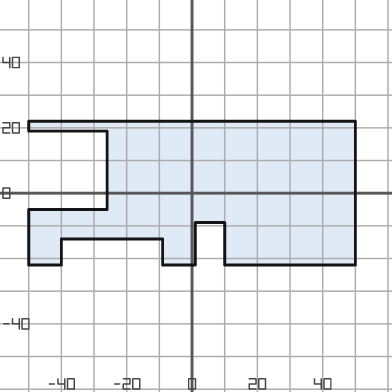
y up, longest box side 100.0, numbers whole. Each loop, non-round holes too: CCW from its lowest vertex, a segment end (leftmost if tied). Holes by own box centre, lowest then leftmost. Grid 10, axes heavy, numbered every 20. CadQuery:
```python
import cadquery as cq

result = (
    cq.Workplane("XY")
    .moveTo(-50.0, -22.0)
    .lineTo(-40.0, -22.0)
    .lineTo(-40.0, -14.0)
    .lineTo(-9.0, -14.0)
    .lineTo(-9.0, -22.0)
    .lineTo(1.0, -22.0)
    .lineTo(1.0, -9.0)
    .lineTo(10.0, -9.0)
    .lineTo(10.0, -22.0)
    .lineTo(50.0, -22.0)
    .lineTo(50.0, 22.0)
    .lineTo(-50.0, 22.0)
    .lineTo(-50.0, 19.0)
    .lineTo(-26.0, 19.0)
    .lineTo(-26.0, -5.0)
    .lineTo(-50.0, -5.0)
    .close()
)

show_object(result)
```